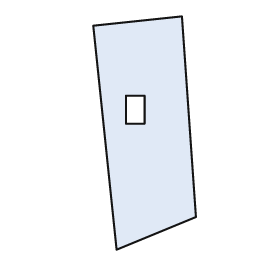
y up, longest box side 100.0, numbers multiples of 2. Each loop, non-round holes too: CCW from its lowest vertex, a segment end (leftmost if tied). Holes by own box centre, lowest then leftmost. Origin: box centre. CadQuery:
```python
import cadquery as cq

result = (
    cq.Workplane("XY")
    .moveTo(-12.0, -50.0)
    .lineTo(22.0, -36.0)
    .lineTo(16.0, 50.0)
    .lineTo(-22.0, 46.0)
    .close()
    .moveTo(-8.0, 4.0)
    .lineTo(0.0, 4.0)
    .lineTo(0.0, 16.0)
    .lineTo(-8.0, 16.0)
    .close()
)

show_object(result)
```